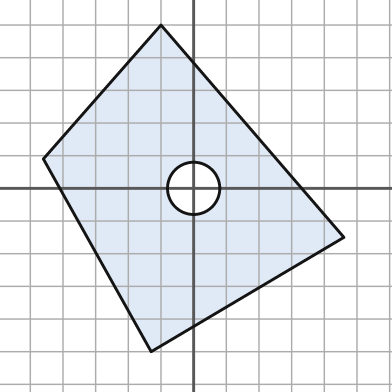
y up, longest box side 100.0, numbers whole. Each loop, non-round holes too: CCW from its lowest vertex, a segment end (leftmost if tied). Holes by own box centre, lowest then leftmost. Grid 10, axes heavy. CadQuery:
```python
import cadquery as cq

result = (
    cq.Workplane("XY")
    .moveTo(-13.0, -50.0)
    .lineTo(46.0, -15.0)
    .lineTo(-10.0, 50.0)
    .lineTo(-46.0, 9.0)
    .close()
    .moveTo(0.0, 0.0)
    .circle(8.0)
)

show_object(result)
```